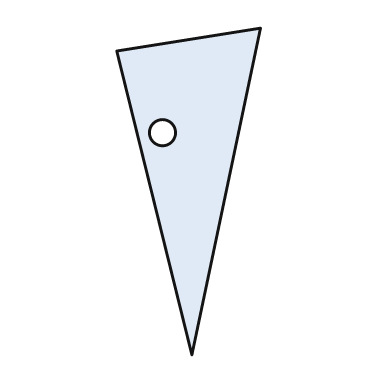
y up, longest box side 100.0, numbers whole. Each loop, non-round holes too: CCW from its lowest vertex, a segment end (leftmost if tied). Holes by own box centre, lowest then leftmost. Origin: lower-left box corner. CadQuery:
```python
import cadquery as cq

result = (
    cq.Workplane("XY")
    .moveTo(23.0, 0.0)
    .lineTo(44.0, 100.0)
    .lineTo(0.0, 93.0)
    .close()
    .moveTo(14.0, 68.0)
    .circle(4.0)
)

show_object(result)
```